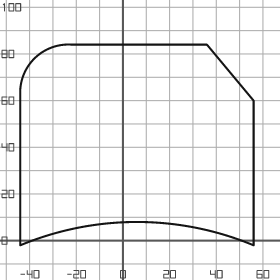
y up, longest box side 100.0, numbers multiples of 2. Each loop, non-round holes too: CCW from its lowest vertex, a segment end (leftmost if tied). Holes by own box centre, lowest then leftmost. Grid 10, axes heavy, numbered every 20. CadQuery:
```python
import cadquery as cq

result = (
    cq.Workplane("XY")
    .moveTo(-44.0, -2.0)
    .threePointArc((6.0, 8.0), (56.0, -2.0))
    .lineTo(56.0, 60.0)
    .lineTo(36.0, 84.0)
    .lineTo(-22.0, 84.0)
    .threePointArc((-38.0, 78.0), (-44.0, 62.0))
    .close()
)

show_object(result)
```